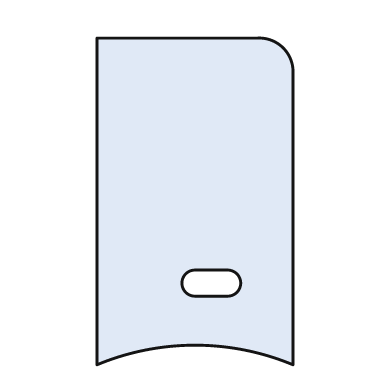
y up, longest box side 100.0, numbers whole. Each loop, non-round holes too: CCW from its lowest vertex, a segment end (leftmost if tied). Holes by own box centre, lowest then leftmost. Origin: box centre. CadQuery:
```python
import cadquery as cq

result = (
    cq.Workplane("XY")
    .moveTo(-30.0, -50.0)
    .threePointArc((0.0, -44.0), (30.0, -50.0))
    .lineTo(30.0, 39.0)
    .threePointArc((27.0, 47.0), (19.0, 50.0))
    .lineTo(-30.0, 50.0)
    .close()
    .moveTo(0.0, -29.0)
    .lineTo(10.0, -29.0)
    .threePointArc((14.0, -25.0), (10.0, -21.0))
    .lineTo(0.0, -21.0)
    .threePointArc((-4.0, -25.0), (0.0, -29.0))
    .close()
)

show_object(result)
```